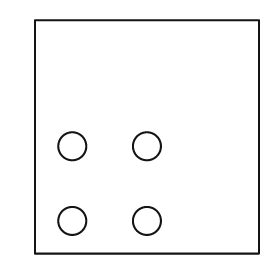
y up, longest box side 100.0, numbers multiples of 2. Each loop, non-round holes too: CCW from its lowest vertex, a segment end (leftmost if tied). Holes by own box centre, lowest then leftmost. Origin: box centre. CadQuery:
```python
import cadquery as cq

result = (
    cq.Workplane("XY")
    .moveTo(-48.0, -50.0)
    .lineTo(48.0, -50.0)
    .lineTo(48.0, 50.0)
    .lineTo(-48.0, 50.0)
    .close()
    .moveTo(-32.0, -36.0)
    .circle(6.0)
    .moveTo(0.0, -36.0)
    .circle(6.0)
    .moveTo(-32.0, -4.0)
    .circle(6.0)
    .moveTo(0.0, -4.0)
    .circle(6.0)
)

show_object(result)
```